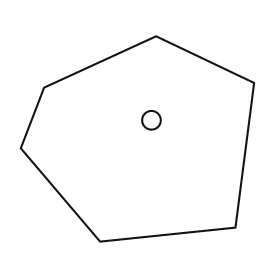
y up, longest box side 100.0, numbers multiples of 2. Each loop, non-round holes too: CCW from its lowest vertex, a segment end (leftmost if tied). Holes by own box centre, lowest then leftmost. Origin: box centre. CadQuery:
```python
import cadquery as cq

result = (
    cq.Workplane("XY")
    .moveTo(-16.0, -44.0)
    .lineTo(42.0, -38.0)
    .lineTo(50.0, 24.0)
    .lineTo(8.0, 44.0)
    .lineTo(-40.0, 22.0)
    .lineTo(-50.0, -4.0)
    .close()
    .moveTo(6.0, 8.0)
    .circle(4.0)
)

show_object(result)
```